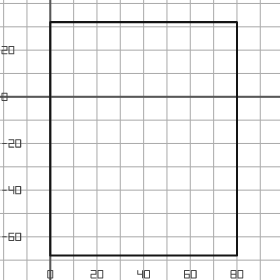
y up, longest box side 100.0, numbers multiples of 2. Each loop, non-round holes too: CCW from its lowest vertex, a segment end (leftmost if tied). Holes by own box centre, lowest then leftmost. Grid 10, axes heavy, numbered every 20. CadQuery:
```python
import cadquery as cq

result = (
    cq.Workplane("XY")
    .moveTo(0.0, -68.0)
    .lineTo(80.0, -68.0)
    .lineTo(80.0, 32.0)
    .lineTo(0.0, 32.0)
    .close()
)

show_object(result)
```